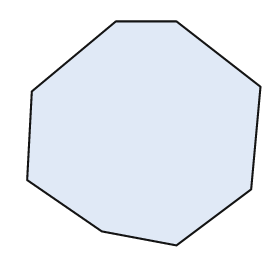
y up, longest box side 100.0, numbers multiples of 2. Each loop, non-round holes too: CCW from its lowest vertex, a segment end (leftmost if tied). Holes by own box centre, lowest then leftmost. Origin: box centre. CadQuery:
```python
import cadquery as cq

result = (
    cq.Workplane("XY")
    .moveTo(14.0, -48.0)
    .lineTo(46.0, -24.0)
    .lineTo(50.0, 20.0)
    .lineTo(14.0, 48.0)
    .lineTo(-12.0, 48.0)
    .lineTo(-48.0, 18.0)
    .lineTo(-50.0, -20.0)
    .lineTo(-18.0, -42.0)
    .close()
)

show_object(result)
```